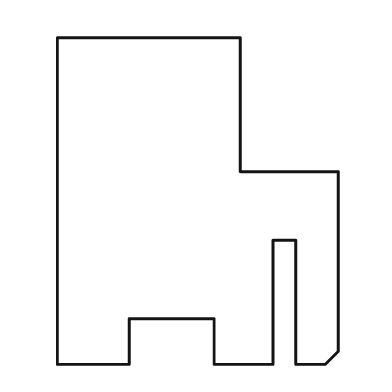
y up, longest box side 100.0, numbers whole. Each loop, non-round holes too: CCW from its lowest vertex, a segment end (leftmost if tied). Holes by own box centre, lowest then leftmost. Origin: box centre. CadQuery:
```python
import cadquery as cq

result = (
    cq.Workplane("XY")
    .moveTo(-43.0, -50.0)
    .lineTo(-21.0, -50.0)
    .lineTo(-21.0, -36.0)
    .lineTo(5.0, -36.0)
    .lineTo(5.0, -50.0)
    .lineTo(23.0, -50.0)
    .lineTo(23.0, -12.0)
    .lineTo(30.0, -12.0)
    .lineTo(30.0, -50.0)
    .lineTo(39.0, -50.0)
    .lineTo(43.0, -46.0)
    .lineTo(43.0, 9.0)
    .lineTo(13.0, 9.0)
    .lineTo(13.0, 50.0)
    .lineTo(-43.0, 50.0)
    .close()
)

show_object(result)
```